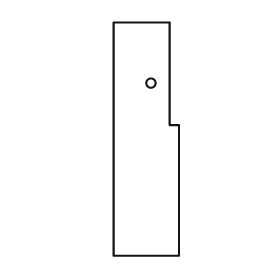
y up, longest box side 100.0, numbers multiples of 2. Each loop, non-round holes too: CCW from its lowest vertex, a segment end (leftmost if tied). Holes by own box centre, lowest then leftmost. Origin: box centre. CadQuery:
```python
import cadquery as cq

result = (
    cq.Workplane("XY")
    .moveTo(-14.0, -50.0)
    .lineTo(14.0, -50.0)
    .lineTo(14.0, 6.0)
    .lineTo(10.0, 6.0)
    .lineTo(10.0, 50.0)
    .lineTo(-14.0, 50.0)
    .close()
    .moveTo(2.0, 24.0)
    .circle(2.0)
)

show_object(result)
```